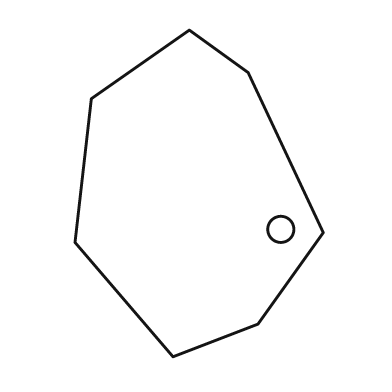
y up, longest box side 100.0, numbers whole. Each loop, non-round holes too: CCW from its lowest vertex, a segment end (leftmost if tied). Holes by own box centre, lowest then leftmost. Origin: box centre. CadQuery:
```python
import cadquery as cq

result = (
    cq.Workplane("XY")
    .moveTo(-8.0, -50.0)
    .lineTo(18.0, -40.0)
    .lineTo(38.0, -12.0)
    .lineTo(15.0, 37.0)
    .lineTo(-3.0, 50.0)
    .lineTo(-33.0, 29.0)
    .lineTo(-38.0, -15.0)
    .close()
    .moveTo(25.0, -11.0)
    .circle(4.0)
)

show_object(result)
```